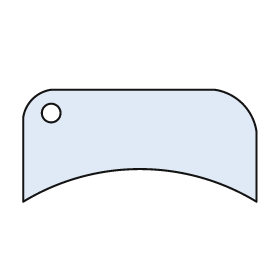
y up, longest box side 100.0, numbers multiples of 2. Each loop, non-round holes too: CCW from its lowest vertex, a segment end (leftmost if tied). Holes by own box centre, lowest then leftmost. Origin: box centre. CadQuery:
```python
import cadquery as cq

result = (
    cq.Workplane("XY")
    .moveTo(-50.0, -24.0)
    .threePointArc((0.0, -10.0), (50.0, -24.0))
    .lineTo(50.0, 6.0)
    .threePointArc((44.0, 18.0), (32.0, 24.0))
    .lineTo(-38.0, 24.0)
    .threePointArc((-46.0, 20.0), (-50.0, 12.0))
    .close()
    .moveTo(-38.0, 14.0)
    .circle(4.0)
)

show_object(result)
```